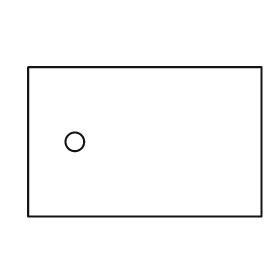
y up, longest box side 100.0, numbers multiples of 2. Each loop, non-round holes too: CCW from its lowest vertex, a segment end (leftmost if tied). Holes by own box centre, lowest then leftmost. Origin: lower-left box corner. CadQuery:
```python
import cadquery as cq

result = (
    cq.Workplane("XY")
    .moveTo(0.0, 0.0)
    .lineTo(100.0, 0.0)
    .lineTo(100.0, 64.0)
    .lineTo(0.0, 64.0)
    .close()
    .moveTo(20.0, 32.0)
    .circle(4.0)
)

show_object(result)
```